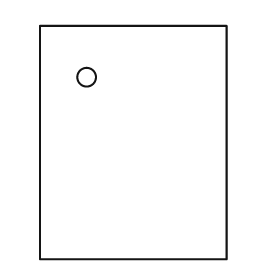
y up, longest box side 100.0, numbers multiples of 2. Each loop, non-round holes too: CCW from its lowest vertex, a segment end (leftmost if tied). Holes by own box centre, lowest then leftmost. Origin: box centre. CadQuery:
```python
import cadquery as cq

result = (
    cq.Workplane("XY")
    .moveTo(-40.0, -50.0)
    .lineTo(40.0, -50.0)
    .lineTo(40.0, 50.0)
    .lineTo(-40.0, 50.0)
    .close()
    .moveTo(-20.0, 28.0)
    .circle(4.0)
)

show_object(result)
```